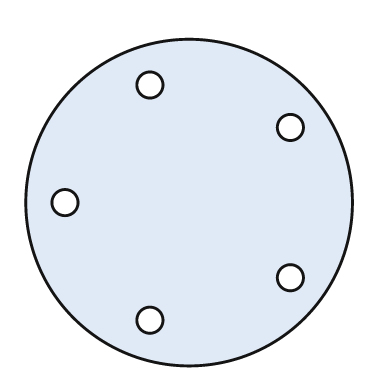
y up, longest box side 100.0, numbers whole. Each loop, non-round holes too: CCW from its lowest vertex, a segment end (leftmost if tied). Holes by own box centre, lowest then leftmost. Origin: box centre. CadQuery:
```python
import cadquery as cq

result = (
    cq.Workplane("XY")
    .moveTo(0.0, 0.0)
    .circle(50.0)
    .moveTo(-12.0, -36.0)
    .circle(4.0)
    .moveTo(31.0, -23.0)
    .circle(4.0)
    .moveTo(-38.0, 0.0)
    .circle(4.0)
    .moveTo(31.0, 23.0)
    .circle(4.0)
    .moveTo(-12.0, 36.0)
    .circle(4.0)
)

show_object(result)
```